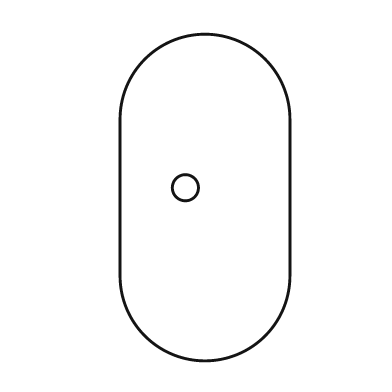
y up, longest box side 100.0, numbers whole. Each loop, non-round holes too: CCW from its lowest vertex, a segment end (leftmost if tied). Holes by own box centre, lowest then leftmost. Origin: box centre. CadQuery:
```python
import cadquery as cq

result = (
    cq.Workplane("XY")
    .moveTo(-26.0, -24.0)
    .threePointArc((0.0, -50.0), (26.0, -24.0))
    .lineTo(26.0, 24.0)
    .threePointArc((0.0, 50.0), (-26.0, 24.0))
    .close()
    .moveTo(-6.0, 3.0)
    .circle(4.0)
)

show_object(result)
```